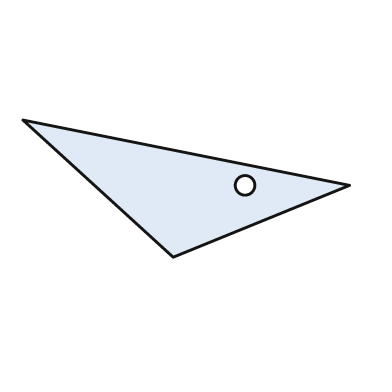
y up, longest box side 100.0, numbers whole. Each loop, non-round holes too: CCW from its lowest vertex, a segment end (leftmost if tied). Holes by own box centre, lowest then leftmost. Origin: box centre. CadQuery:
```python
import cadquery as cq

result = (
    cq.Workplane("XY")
    .moveTo(-4.0, -21.0)
    .lineTo(50.0, 1.0)
    .lineTo(-50.0, 21.0)
    .close()
    .moveTo(18.0, 1.0)
    .circle(3.0)
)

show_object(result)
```